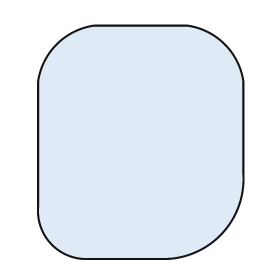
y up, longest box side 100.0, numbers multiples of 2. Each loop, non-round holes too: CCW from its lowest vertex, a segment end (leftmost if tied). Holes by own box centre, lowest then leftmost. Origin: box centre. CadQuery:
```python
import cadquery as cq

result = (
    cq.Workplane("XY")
    .moveTo(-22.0, -50.0)
    .lineTo(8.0, -50.0)
    .threePointArc((34.0, -40.0), (44.0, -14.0))
    .lineTo(44.0, 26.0)
    .threePointArc((36.0, 42.0), (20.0, 50.0))
    .lineTo(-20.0, 50.0)
    .threePointArc((-36.0, 42.0), (-44.0, 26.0))
    .lineTo(-44.0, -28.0)
    .threePointArc((-38.0, -44.0), (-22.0, -50.0))
    .close()
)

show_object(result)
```